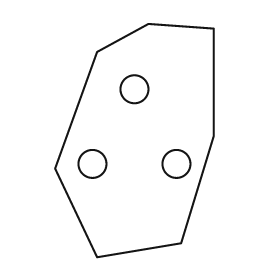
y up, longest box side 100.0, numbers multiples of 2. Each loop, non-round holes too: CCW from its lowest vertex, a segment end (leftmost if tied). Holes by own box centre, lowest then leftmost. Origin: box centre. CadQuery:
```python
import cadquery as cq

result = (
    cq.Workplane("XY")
    .moveTo(-16.0, -50.0)
    .lineTo(20.0, -44.0)
    .lineTo(34.0, 2.0)
    .lineTo(34.0, 48.0)
    .lineTo(6.0, 50.0)
    .lineTo(-16.0, 38.0)
    .lineTo(-34.0, -12.0)
    .close()
    .moveTo(-18.0, -10.0)
    .circle(6.0)
    .moveTo(18.0, -10.0)
    .circle(6.0)
    .moveTo(0.0, 22.0)
    .circle(6.0)
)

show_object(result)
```